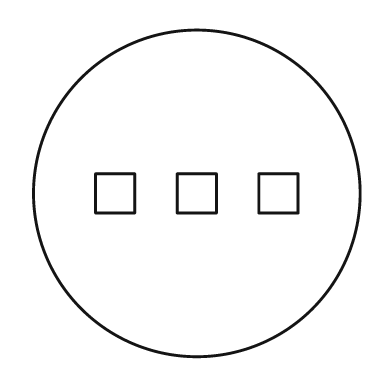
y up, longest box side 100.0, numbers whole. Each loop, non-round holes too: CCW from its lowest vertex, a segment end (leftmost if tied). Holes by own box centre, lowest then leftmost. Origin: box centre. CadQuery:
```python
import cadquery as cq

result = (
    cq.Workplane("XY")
    .moveTo(0.0, 0.0)
    .circle(50.0)
    .moveTo(-31.0, -6.0)
    .lineTo(-19.0, -6.0)
    .lineTo(-19.0, 6.0)
    .lineTo(-31.0, 6.0)
    .close()
    .moveTo(-6.0, -6.0)
    .lineTo(6.0, -6.0)
    .lineTo(6.0, 6.0)
    .lineTo(-6.0, 6.0)
    .close()
    .moveTo(19.0, -6.0)
    .lineTo(31.0, -6.0)
    .lineTo(31.0, 6.0)
    .lineTo(19.0, 6.0)
    .close()
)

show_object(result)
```